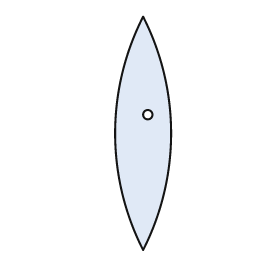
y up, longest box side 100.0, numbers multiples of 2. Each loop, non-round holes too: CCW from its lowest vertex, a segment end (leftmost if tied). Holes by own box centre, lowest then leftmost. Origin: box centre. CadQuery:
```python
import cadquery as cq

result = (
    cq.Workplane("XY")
    .moveTo(0.0, -50.0)
    .threePointArc((12.0, 0.0), (0.0, 50.0))
    .threePointArc((-12.0, 0.0), (0.0, -50.0))
    .close()
    .moveTo(2.0, 8.0)
    .circle(2.0)
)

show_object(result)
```